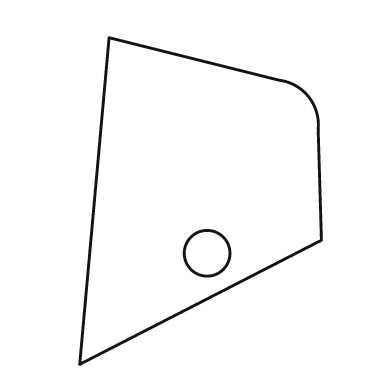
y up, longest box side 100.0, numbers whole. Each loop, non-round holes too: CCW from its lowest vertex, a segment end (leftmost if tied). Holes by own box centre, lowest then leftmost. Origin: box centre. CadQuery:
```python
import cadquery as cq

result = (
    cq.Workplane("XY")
    .moveTo(-37.0, -50.0)
    .lineTo(37.0, -12.0)
    .lineTo(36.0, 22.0)
    .threePointArc((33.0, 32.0), (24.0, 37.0))
    .lineTo(-28.0, 50.0)
    .close()
    .moveTo(2.0, -16.0)
    .circle(7.0)
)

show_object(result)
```